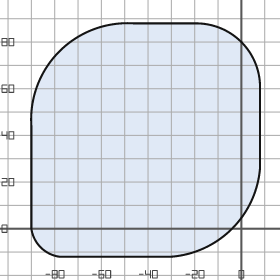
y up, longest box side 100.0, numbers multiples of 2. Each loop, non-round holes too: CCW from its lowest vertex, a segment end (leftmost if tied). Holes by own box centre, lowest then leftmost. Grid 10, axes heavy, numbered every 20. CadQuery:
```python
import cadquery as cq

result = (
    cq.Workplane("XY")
    .moveTo(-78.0, -12.0)
    .lineTo(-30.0, -12.0)
    .threePointArc((-4.0, 0.0), (8.0, 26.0))
    .lineTo(8.0, 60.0)
    .threePointArc((0.0, 80.0), (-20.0, 88.0))
    .lineTo(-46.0, 88.0)
    .threePointArc((-78.0, 76.0), (-90.0, 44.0))
    .lineTo(-90.0, 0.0)
    .threePointArc((-86.0, -8.0), (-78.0, -12.0))
    .close()
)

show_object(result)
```